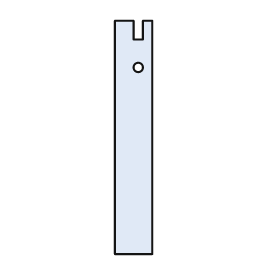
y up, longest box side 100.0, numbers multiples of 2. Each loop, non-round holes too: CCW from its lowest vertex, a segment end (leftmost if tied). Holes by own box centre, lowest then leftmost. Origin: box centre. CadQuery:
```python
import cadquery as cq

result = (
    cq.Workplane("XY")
    .moveTo(-8.0, -50.0)
    .lineTo(8.0, -50.0)
    .lineTo(8.0, 50.0)
    .lineTo(4.0, 50.0)
    .lineTo(4.0, 42.0)
    .lineTo(0.0, 42.0)
    .lineTo(0.0, 50.0)
    .lineTo(-8.0, 50.0)
    .close()
    .moveTo(2.0, 30.0)
    .circle(2.0)
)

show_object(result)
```